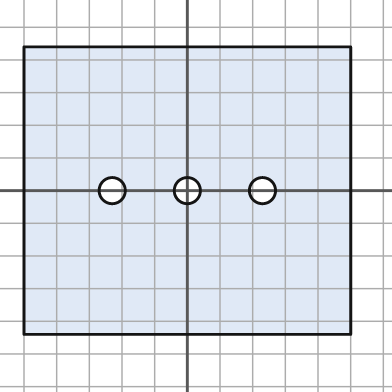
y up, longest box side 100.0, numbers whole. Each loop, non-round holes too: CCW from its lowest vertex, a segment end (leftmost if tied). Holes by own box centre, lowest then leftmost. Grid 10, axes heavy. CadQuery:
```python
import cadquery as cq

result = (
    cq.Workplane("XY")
    .moveTo(-50.0, -44.0)
    .lineTo(50.0, -44.0)
    .lineTo(50.0, 44.0)
    .lineTo(-50.0, 44.0)
    .close()
    .moveTo(-23.0, 0.0)
    .circle(4.0)
    .moveTo(0.0, 0.0)
    .circle(4.0)
    .moveTo(23.0, 0.0)
    .circle(4.0)
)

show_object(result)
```